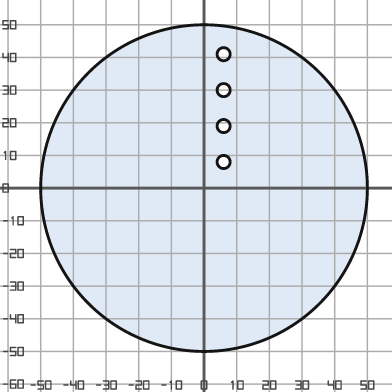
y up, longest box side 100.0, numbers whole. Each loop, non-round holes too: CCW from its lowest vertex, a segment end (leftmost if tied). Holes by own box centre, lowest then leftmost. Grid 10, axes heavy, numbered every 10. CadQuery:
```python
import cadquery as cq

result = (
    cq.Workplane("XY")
    .moveTo(0.0, 0.0)
    .circle(50.0)
    .moveTo(6.0, 8.0)
    .circle(2.0)
    .moveTo(6.0, 19.0)
    .circle(2.0)
    .moveTo(6.0, 30.0)
    .circle(2.0)
    .moveTo(6.0, 41.0)
    .circle(2.0)
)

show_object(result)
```